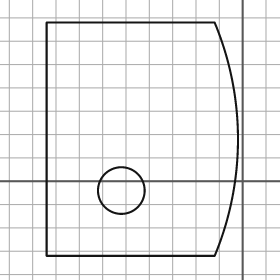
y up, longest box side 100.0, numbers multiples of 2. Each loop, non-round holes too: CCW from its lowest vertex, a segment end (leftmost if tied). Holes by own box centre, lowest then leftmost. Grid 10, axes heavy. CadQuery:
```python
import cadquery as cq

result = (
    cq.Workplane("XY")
    .moveTo(-84.0, -32.0)
    .lineTo(-12.0, -32.0)
    .threePointArc((-2.0, 18.0), (-12.0, 68.0))
    .lineTo(-84.0, 68.0)
    .close()
    .moveTo(-52.0, -4.0)
    .circle(10.0)
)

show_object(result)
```